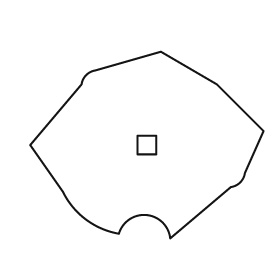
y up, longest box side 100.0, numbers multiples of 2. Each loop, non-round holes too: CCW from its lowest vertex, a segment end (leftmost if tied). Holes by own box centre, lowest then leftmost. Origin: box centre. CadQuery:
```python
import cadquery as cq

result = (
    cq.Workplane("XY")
    .moveTo(10.0, -40.0)
    .lineTo(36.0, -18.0)
    .threePointArc((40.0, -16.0), (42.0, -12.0))
    .lineTo(50.0, 6.0)
    .lineTo(30.0, 26.0)
    .lineTo(6.0, 40.0)
    .lineTo(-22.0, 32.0)
    .threePointArc((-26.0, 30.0), (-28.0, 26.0))
    .lineTo(-50.0, 0.0)
    .lineTo(-36.0, -20.0)
    .threePointArc((-26.0, -32.0), (-12.0, -38.0))
    .threePointArc((0.0, -30.0), (10.0, -40.0))
    .close()
    .moveTo(-4.0, -4.0)
    .lineTo(4.0, -4.0)
    .lineTo(4.0, 4.0)
    .lineTo(-4.0, 4.0)
    .close()
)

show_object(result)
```